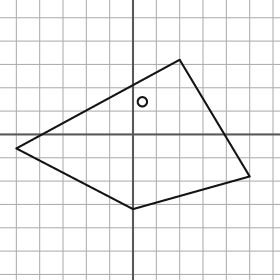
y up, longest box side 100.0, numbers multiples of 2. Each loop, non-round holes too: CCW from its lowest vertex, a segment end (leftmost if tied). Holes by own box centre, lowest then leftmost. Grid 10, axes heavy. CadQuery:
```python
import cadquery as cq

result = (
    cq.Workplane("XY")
    .moveTo(0.0, -32.0)
    .lineTo(50.0, -18.0)
    .lineTo(20.0, 32.0)
    .lineTo(-50.0, -6.0)
    .close()
    .moveTo(4.0, 14.0)
    .circle(2.0)
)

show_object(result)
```